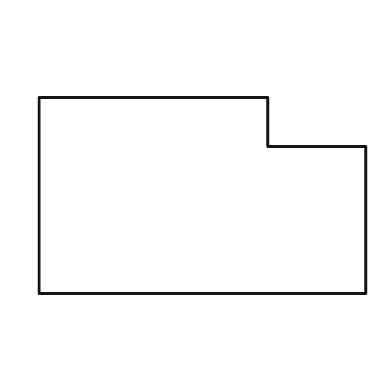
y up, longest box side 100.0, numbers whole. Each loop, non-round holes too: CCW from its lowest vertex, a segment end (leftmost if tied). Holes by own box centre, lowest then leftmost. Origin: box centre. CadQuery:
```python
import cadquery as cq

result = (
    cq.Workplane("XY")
    .moveTo(-50.0, -30.0)
    .lineTo(50.0, -30.0)
    .lineTo(50.0, 15.0)
    .lineTo(20.0, 15.0)
    .lineTo(20.0, 30.0)
    .lineTo(-50.0, 30.0)
    .close()
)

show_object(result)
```